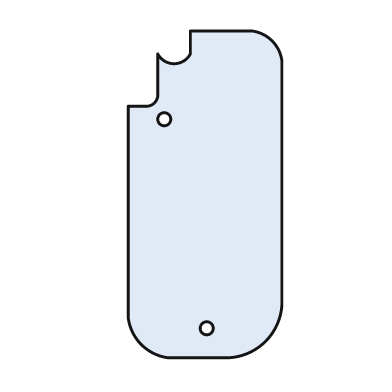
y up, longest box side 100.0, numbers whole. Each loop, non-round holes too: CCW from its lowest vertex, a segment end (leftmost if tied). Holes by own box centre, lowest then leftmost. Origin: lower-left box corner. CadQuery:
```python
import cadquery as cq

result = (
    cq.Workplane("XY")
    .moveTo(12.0, 0.0)
    .lineTo(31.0, 0.0)
    .threePointArc((42.0, 5.0), (47.0, 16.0))
    .lineTo(47.0, 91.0)
    .threePointArc((44.0, 97.0), (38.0, 100.0))
    .lineTo(19.0, 100.0)
    .lineTo(19.0, 93.0)
    .threePointArc((14.0, 90.0), (9.0, 93.0))
    .lineTo(9.0, 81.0)
    .threePointArc((8.0, 78.0), (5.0, 77.0))
    .lineTo(0.0, 77.0)
    .lineTo(0.0, 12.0)
    .threePointArc((4.0, 4.0), (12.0, 0.0))
    .close()
    .moveTo(24.0, 9.0)
    .circle(2.0)
    .moveTo(11.0, 73.0)
    .circle(2.0)
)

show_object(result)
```